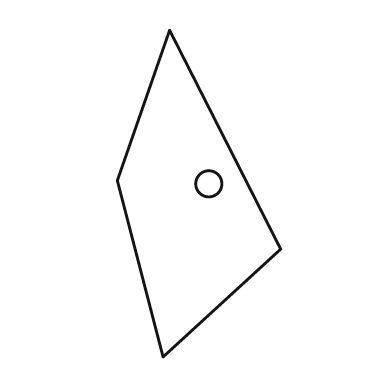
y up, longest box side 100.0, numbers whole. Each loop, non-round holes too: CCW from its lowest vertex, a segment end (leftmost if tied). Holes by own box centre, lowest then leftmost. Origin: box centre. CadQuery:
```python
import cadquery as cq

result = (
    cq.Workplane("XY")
    .moveTo(-11.0, -50.0)
    .lineTo(25.0, -17.0)
    .lineTo(-9.0, 50.0)
    .lineTo(-25.0, 4.0)
    .close()
    .moveTo(3.0, 3.0)
    .circle(4.0)
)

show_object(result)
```